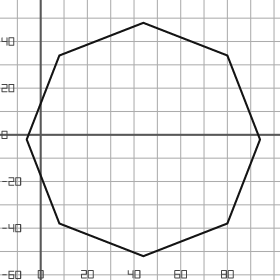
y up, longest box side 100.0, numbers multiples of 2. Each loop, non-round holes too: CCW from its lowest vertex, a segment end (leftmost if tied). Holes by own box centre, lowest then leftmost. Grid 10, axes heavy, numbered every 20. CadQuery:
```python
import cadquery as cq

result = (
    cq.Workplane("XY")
    .moveTo(44.0, -52.0)
    .lineTo(80.0, -38.0)
    .lineTo(94.0, -2.0)
    .lineTo(80.0, 34.0)
    .lineTo(44.0, 48.0)
    .lineTo(8.0, 34.0)
    .lineTo(-6.0, -2.0)
    .lineTo(8.0, -38.0)
    .close()
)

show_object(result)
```